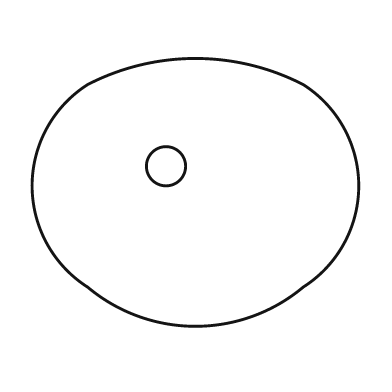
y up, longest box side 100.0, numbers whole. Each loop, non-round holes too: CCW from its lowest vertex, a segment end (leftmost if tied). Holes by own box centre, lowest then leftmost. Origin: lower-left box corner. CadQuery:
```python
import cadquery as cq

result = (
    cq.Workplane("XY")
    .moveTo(17.0, 12.0)
    .threePointArc((50.0, 0.0), (83.0, 12.0))
    .threePointArc((100.0, 43.0), (83.0, 74.0))
    .threePointArc((50.0, 82.0), (17.0, 74.0))
    .threePointArc((0.0, 43.0), (17.0, 12.0))
    .close()
    .moveTo(41.0, 49.0)
    .circle(6.0)
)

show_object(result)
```